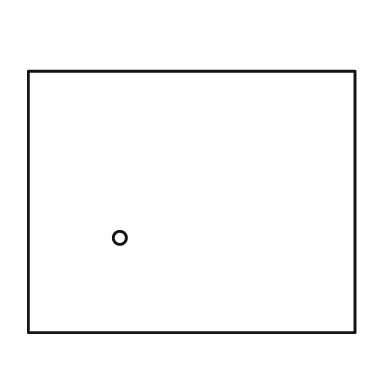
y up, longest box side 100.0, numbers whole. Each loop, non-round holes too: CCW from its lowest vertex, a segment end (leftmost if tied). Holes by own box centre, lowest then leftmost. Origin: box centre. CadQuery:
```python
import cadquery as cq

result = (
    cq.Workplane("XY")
    .moveTo(-50.0, -40.0)
    .lineTo(50.0, -40.0)
    .lineTo(50.0, 40.0)
    .lineTo(-50.0, 40.0)
    .close()
    .moveTo(-22.0, -11.0)
    .circle(2.0)
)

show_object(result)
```